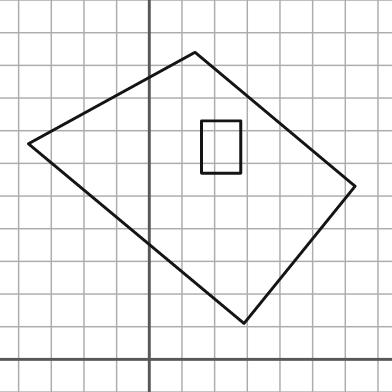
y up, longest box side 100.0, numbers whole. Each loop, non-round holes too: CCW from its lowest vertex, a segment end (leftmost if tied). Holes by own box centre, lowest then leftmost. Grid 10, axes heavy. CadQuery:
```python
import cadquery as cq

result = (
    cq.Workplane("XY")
    .moveTo(29.0, 11.0)
    .lineTo(63.0, 53.0)
    .lineTo(14.0, 94.0)
    .lineTo(-37.0, 66.0)
    .close()
    .moveTo(16.0, 57.0)
    .lineTo(28.0, 57.0)
    .lineTo(28.0, 73.0)
    .lineTo(16.0, 73.0)
    .close()
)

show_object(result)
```